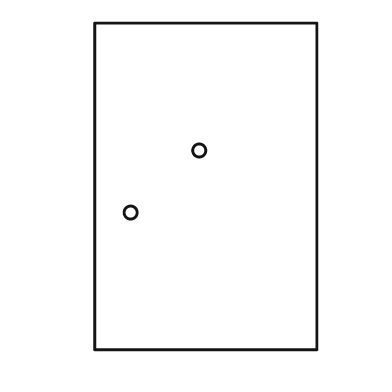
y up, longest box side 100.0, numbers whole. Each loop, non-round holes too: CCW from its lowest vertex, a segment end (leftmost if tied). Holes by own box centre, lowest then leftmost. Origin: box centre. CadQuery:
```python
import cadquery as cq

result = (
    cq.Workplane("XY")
    .moveTo(-34.0, -50.0)
    .lineTo(34.0, -50.0)
    .lineTo(34.0, 50.0)
    .lineTo(-34.0, 50.0)
    .close()
    .moveTo(-23.0, -8.0)
    .circle(2.0)
    .moveTo(-2.0, 11.0)
    .circle(2.0)
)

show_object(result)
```